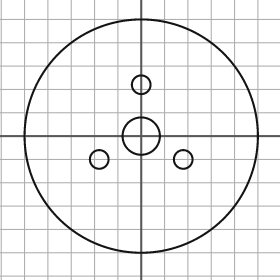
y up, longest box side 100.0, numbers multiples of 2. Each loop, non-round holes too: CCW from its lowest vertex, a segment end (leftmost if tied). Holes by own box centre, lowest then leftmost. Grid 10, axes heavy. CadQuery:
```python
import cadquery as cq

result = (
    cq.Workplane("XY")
    .moveTo(0.0, 0.0)
    .circle(50.0)
    .moveTo(-18.0, -10.0)
    .circle(4.0)
    .moveTo(18.0, -10.0)
    .circle(4.0)
    .moveTo(0.0, 0.0)
    .circle(8.0)
    .moveTo(0.0, 22.0)
    .circle(4.0)
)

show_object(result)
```